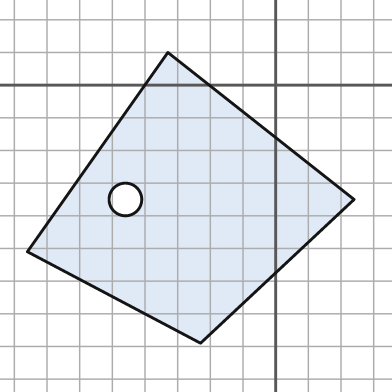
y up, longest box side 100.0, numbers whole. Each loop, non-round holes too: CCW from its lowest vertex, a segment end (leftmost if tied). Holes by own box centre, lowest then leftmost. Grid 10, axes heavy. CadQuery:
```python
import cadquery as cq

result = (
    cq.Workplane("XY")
    .moveTo(-23.0, -79.0)
    .lineTo(24.0, -35.0)
    .lineTo(-33.0, 10.0)
    .lineTo(-76.0, -51.0)
    .close()
    .moveTo(-46.0, -35.0)
    .circle(5.0)
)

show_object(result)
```